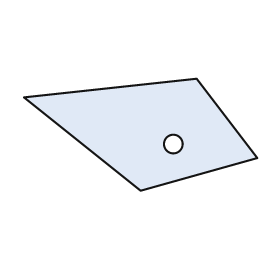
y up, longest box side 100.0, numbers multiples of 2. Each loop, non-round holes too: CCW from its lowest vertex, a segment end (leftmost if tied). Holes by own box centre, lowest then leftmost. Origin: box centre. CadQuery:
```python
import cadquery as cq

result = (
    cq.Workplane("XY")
    .moveTo(0.0, -24.0)
    .lineTo(50.0, -10.0)
    .lineTo(24.0, 24.0)
    .lineTo(-50.0, 16.0)
    .close()
    .moveTo(14.0, -4.0)
    .circle(4.0)
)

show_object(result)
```